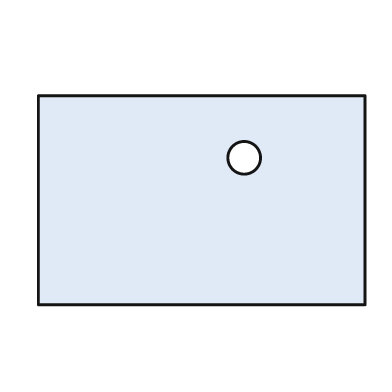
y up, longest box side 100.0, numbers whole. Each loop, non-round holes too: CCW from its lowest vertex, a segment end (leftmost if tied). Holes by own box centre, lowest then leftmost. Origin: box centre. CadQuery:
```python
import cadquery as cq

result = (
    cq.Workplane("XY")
    .moveTo(-50.0, -32.0)
    .lineTo(50.0, -32.0)
    .lineTo(50.0, 32.0)
    .lineTo(-50.0, 32.0)
    .close()
    .moveTo(13.0, 13.0)
    .circle(5.0)
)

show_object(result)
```